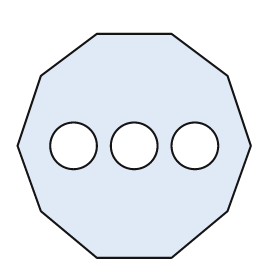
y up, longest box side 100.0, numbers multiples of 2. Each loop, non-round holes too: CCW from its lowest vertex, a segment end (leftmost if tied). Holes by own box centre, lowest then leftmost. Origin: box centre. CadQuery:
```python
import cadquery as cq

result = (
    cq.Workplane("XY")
    .moveTo(-16.0, -48.0)
    .lineTo(16.0, -48.0)
    .lineTo(40.0, -28.0)
    .lineTo(50.0, 0.0)
    .lineTo(40.0, 30.0)
    .lineTo(16.0, 48.0)
    .lineTo(-16.0, 48.0)
    .lineTo(-40.0, 30.0)
    .lineTo(-50.0, 0.0)
    .lineTo(-40.0, -28.0)
    .close()
    .moveTo(-26.0, 0.0)
    .circle(10.0)
    .moveTo(0.0, 0.0)
    .circle(10.0)
    .moveTo(26.0, 0.0)
    .circle(10.0)
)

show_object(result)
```